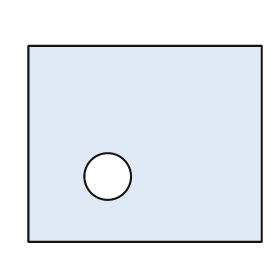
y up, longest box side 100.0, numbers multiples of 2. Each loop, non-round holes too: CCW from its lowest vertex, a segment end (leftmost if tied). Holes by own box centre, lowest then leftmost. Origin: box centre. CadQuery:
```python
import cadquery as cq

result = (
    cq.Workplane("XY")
    .moveTo(-50.0, -42.0)
    .lineTo(50.0, -42.0)
    .lineTo(50.0, 42.0)
    .lineTo(-50.0, 42.0)
    .close()
    .moveTo(-16.0, -14.0)
    .circle(10.0)
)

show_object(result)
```